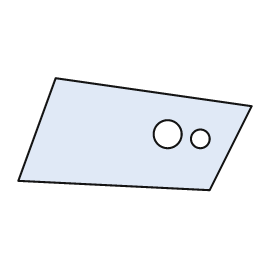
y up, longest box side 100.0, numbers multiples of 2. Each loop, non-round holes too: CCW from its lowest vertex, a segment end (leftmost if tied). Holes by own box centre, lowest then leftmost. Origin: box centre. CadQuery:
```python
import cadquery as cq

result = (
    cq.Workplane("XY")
    .moveTo(32.0, -24.0)
    .lineTo(50.0, 12.0)
    .lineTo(-34.0, 24.0)
    .lineTo(-50.0, -20.0)
    .close()
    .moveTo(28.0, -2.0)
    .circle(4.0)
    .moveTo(14.0, 0.0)
    .circle(6.0)
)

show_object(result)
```